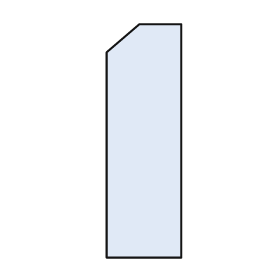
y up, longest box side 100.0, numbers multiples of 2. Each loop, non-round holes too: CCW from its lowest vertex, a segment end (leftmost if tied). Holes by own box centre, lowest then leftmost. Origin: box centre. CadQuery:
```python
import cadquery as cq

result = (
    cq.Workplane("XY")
    .moveTo(-16.0, -50.0)
    .lineTo(16.0, -50.0)
    .lineTo(16.0, 50.0)
    .lineTo(-2.0, 50.0)
    .lineTo(-16.0, 38.0)
    .close()
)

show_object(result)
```